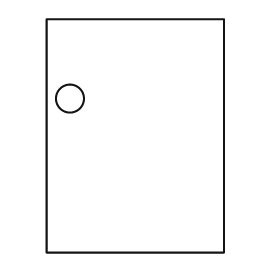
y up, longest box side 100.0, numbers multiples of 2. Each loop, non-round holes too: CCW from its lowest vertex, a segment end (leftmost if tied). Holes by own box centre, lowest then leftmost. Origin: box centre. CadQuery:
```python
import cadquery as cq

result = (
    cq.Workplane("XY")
    .moveTo(-38.0, -50.0)
    .lineTo(38.0, -50.0)
    .lineTo(38.0, 50.0)
    .lineTo(-38.0, 50.0)
    .close()
    .moveTo(-28.0, 16.0)
    .circle(6.0)
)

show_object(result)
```